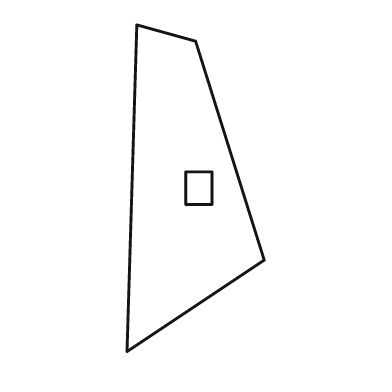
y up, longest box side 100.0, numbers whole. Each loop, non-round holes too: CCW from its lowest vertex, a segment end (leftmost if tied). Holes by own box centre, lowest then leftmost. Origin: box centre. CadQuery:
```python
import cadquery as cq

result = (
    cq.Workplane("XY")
    .moveTo(-21.0, -50.0)
    .lineTo(21.0, -22.0)
    .lineTo(0.0, 45.0)
    .lineTo(-18.0, 50.0)
    .close()
    .moveTo(-3.0, -5.0)
    .lineTo(5.0, -5.0)
    .lineTo(5.0, 5.0)
    .lineTo(-3.0, 5.0)
    .close()
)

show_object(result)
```